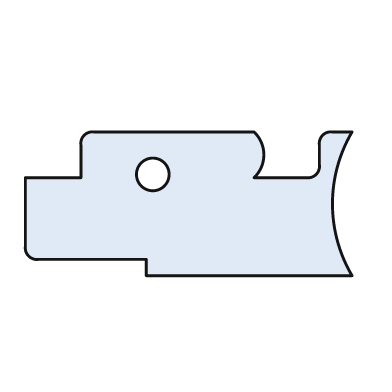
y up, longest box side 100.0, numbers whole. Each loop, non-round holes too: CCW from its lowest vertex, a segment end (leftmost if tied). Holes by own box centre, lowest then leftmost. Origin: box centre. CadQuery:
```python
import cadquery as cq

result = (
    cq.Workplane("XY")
    .moveTo(-13.0, -22.0)
    .lineTo(50.0, -22.0)
    .threePointArc((44.0, 0.0), (50.0, 22.0))
    .lineTo(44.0, 22.0)
    .threePointArc((41.0, 21.0), (40.0, 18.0))
    .lineTo(40.0, 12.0)
    .threePointArc((39.0, 9.0), (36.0, 8.0))
    .lineTo(20.0, 8.0)
    .threePointArc((23.0, 15.0), (20.0, 22.0))
    .lineTo(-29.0, 22.0)
    .threePointArc((-32.0, 21.0), (-33.0, 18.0))
    .lineTo(-33.0, 8.0)
    .lineTo(-50.0, 8.0)
    .lineTo(-50.0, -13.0)
    .threePointArc((-49.0, -16.0), (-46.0, -17.0))
    .lineTo(-13.0, -17.0)
    .close()
    .moveTo(-11.0, 9.0)
    .circle(5.0)
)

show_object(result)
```